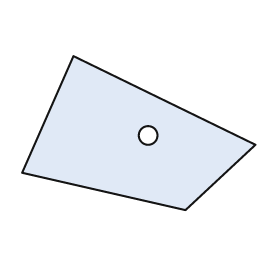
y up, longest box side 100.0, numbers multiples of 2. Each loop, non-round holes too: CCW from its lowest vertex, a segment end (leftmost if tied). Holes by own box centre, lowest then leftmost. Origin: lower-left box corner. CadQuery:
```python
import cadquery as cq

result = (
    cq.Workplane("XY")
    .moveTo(70.0, 0.0)
    .lineTo(100.0, 28.0)
    .lineTo(22.0, 66.0)
    .lineTo(0.0, 16.0)
    .close()
    .moveTo(54.0, 32.0)
    .circle(4.0)
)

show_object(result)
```